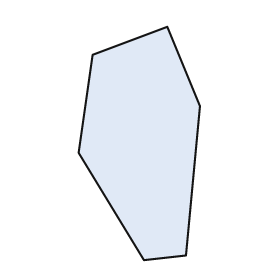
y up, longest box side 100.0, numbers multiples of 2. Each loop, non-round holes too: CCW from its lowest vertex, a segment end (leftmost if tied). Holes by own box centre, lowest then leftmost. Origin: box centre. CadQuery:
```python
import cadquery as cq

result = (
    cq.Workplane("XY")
    .moveTo(2.0, -50.0)
    .lineTo(20.0, -48.0)
    .lineTo(26.0, 16.0)
    .lineTo(12.0, 50.0)
    .lineTo(-20.0, 38.0)
    .lineTo(-26.0, -4.0)
    .close()
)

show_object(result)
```